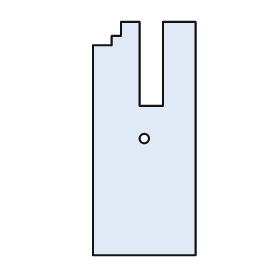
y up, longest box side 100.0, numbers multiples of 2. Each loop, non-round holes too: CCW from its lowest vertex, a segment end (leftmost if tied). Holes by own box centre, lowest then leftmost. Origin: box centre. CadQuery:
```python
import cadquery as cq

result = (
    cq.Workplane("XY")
    .moveTo(-22.0, -50.0)
    .lineTo(22.0, -50.0)
    .lineTo(22.0, 50.0)
    .lineTo(8.0, 50.0)
    .lineTo(8.0, 14.0)
    .lineTo(-2.0, 14.0)
    .lineTo(-2.0, 50.0)
    .lineTo(-10.0, 50.0)
    .lineTo(-10.0, 44.0)
    .lineTo(-14.0, 44.0)
    .lineTo(-14.0, 40.0)
    .lineTo(-22.0, 40.0)
    .close()
    .moveTo(0.0, 0.0)
    .circle(2.0)
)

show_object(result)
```